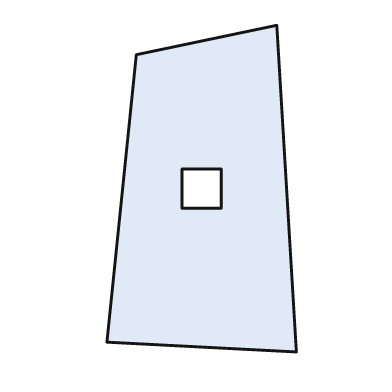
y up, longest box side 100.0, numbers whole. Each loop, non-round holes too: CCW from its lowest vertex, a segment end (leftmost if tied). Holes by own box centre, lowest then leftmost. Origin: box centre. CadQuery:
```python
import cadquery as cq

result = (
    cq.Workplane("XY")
    .moveTo(29.0, -50.0)
    .lineTo(23.0, 50.0)
    .lineTo(-20.0, 41.0)
    .lineTo(-29.0, -47.0)
    .close()
    .moveTo(-6.0, -6.0)
    .lineTo(6.0, -6.0)
    .lineTo(6.0, 6.0)
    .lineTo(-6.0, 6.0)
    .close()
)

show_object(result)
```